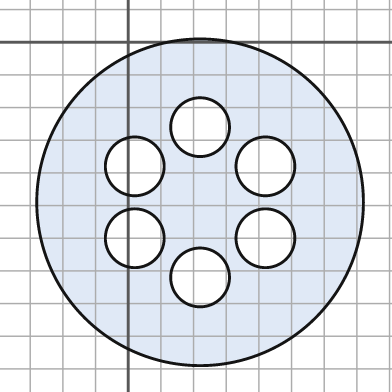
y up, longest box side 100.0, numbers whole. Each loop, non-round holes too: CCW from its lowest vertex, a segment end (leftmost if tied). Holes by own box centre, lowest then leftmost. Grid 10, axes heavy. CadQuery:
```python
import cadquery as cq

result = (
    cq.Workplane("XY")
    .moveTo(22.0, -49.0)
    .circle(50.0)
    .moveTo(22.0, -72.0)
    .circle(9.0)
    .moveTo(2.0, -60.0)
    .circle(9.0)
    .moveTo(42.0, -60.0)
    .circle(9.0)
    .moveTo(2.0, -38.0)
    .circle(9.0)
    .moveTo(42.0, -38.0)
    .circle(9.0)
    .moveTo(22.0, -26.0)
    .circle(9.0)
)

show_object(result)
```